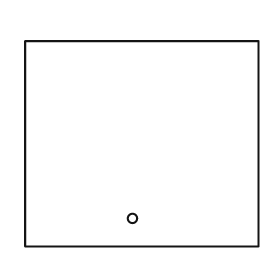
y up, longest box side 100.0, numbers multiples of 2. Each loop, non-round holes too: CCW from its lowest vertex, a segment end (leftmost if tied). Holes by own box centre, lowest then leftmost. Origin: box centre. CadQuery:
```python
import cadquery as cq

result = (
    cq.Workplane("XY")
    .moveTo(-50.0, -44.0)
    .lineTo(50.0, -44.0)
    .lineTo(50.0, 44.0)
    .lineTo(-50.0, 44.0)
    .close()
    .moveTo(-4.0, -32.0)
    .circle(2.0)
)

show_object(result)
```